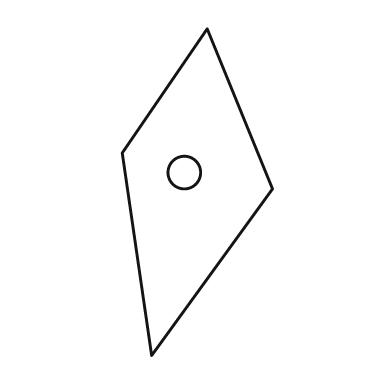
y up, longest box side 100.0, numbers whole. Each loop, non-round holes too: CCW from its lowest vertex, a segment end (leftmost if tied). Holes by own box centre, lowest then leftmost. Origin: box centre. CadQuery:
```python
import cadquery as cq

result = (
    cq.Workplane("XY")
    .moveTo(-14.0, -50.0)
    .lineTo(23.0, 1.0)
    .lineTo(3.0, 50.0)
    .lineTo(-23.0, 12.0)
    .close()
    .moveTo(-4.0, 6.0)
    .circle(5.0)
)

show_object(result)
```